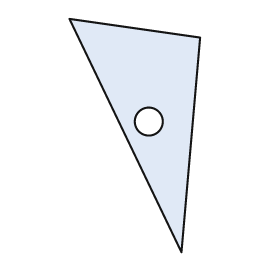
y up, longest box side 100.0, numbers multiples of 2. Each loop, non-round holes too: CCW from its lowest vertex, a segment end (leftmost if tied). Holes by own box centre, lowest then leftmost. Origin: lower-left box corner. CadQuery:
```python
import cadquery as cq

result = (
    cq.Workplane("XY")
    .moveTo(48.0, 0.0)
    .lineTo(56.0, 92.0)
    .lineTo(0.0, 100.0)
    .close()
    .moveTo(34.0, 56.0)
    .circle(6.0)
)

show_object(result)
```